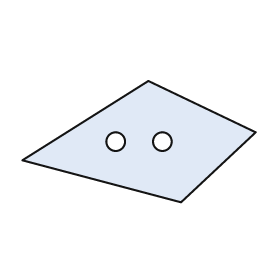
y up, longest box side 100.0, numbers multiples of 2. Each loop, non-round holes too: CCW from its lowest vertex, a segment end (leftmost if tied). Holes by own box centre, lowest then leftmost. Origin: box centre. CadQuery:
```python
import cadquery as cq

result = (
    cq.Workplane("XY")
    .moveTo(18.0, -26.0)
    .lineTo(50.0, 4.0)
    .lineTo(4.0, 26.0)
    .lineTo(-50.0, -8.0)
    .close()
    .moveTo(-10.0, 0.0)
    .circle(4.0)
    .moveTo(10.0, 0.0)
    .circle(4.0)
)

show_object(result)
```